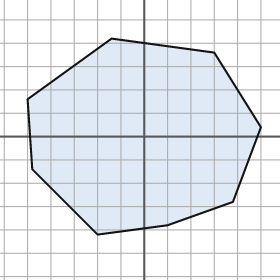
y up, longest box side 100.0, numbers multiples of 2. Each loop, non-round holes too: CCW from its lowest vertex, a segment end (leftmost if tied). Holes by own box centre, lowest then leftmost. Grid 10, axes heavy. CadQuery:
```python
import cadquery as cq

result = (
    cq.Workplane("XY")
    .moveTo(-20.0, -42.0)
    .lineTo(10.0, -38.0)
    .lineTo(38.0, -28.0)
    .lineTo(50.0, 4.0)
    .lineTo(30.0, 36.0)
    .lineTo(-14.0, 42.0)
    .lineTo(-50.0, 16.0)
    .lineTo(-48.0, -14.0)
    .close()
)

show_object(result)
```